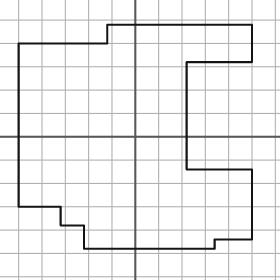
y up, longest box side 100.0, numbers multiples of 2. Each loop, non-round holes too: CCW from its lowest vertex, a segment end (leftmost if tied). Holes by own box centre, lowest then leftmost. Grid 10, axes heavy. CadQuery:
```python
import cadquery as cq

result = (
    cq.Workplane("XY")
    .moveTo(-22.0, -48.0)
    .lineTo(34.0, -48.0)
    .lineTo(34.0, -44.0)
    .lineTo(50.0, -44.0)
    .lineTo(50.0, -14.0)
    .lineTo(22.0, -14.0)
    .lineTo(22.0, 32.0)
    .lineTo(50.0, 32.0)
    .lineTo(50.0, 48.0)
    .lineTo(-12.0, 48.0)
    .lineTo(-12.0, 40.0)
    .lineTo(-50.0, 40.0)
    .lineTo(-50.0, -30.0)
    .lineTo(-32.0, -30.0)
    .lineTo(-32.0, -38.0)
    .lineTo(-22.0, -38.0)
    .close()
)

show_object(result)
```